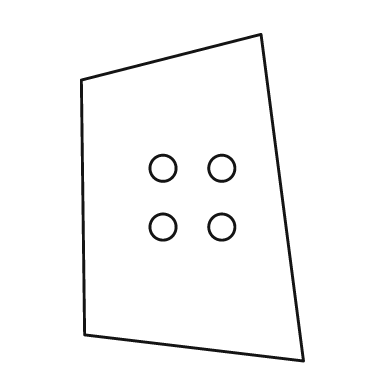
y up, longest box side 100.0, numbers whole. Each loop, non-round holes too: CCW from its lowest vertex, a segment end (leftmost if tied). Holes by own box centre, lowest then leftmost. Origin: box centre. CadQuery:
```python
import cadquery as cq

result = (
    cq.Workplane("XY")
    .moveTo(34.0, -50.0)
    .lineTo(21.0, 50.0)
    .lineTo(-34.0, 36.0)
    .lineTo(-33.0, -42.0)
    .close()
    .moveTo(-9.0, -9.0)
    .circle(4.0)
    .moveTo(9.0, -9.0)
    .circle(4.0)
    .moveTo(-9.0, 9.0)
    .circle(4.0)
    .moveTo(9.0, 9.0)
    .circle(4.0)
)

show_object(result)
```